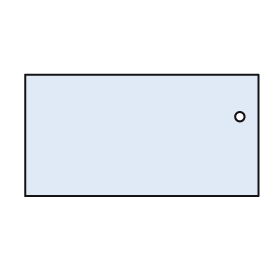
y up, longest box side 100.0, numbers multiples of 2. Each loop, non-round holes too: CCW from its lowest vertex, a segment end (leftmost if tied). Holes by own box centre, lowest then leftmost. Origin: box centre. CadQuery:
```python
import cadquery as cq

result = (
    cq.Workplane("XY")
    .moveTo(-50.0, -26.0)
    .lineTo(50.0, -26.0)
    .lineTo(50.0, 26.0)
    .lineTo(-50.0, 26.0)
    .close()
    .moveTo(42.0, 8.0)
    .circle(2.0)
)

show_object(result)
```